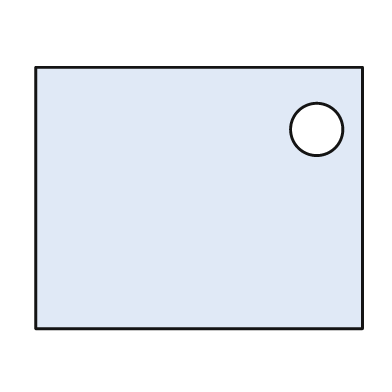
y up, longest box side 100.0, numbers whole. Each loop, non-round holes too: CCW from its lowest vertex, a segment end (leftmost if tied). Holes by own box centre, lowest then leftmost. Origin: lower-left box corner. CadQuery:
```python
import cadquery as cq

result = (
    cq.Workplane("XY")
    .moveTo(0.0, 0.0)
    .lineTo(100.0, 0.0)
    .lineTo(100.0, 80.0)
    .lineTo(0.0, 80.0)
    .close()
    .moveTo(86.0, 61.0)
    .circle(8.0)
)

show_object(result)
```